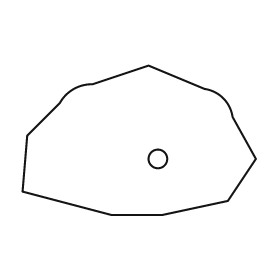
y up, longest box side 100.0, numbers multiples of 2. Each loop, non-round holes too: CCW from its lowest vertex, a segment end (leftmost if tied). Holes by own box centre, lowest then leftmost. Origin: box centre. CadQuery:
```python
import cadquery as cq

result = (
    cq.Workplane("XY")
    .moveTo(-12.0, -32.0)
    .lineTo(10.0, -32.0)
    .lineTo(38.0, -26.0)
    .lineTo(50.0, -8.0)
    .lineTo(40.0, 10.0)
    .threePointArc((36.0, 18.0), (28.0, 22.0))
    .lineTo(4.0, 32.0)
    .lineTo(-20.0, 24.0)
    .threePointArc((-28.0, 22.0), (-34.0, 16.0))
    .lineTo(-48.0, 2.0)
    .lineTo(-50.0, -22.0)
    .close()
    .moveTo(8.0, -8.0)
    .circle(4.0)
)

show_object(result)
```